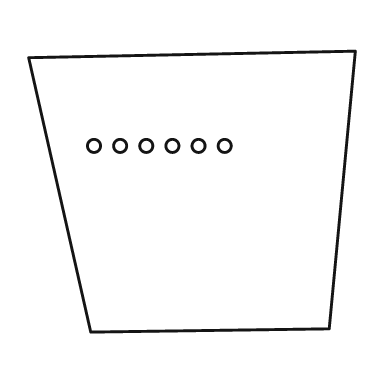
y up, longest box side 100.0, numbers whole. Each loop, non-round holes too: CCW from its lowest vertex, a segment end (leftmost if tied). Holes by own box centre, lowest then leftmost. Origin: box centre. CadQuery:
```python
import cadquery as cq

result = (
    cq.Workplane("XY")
    .moveTo(-31.0, -43.0)
    .lineTo(42.0, -42.0)
    .lineTo(50.0, 43.0)
    .lineTo(-50.0, 41.0)
    .close()
    .moveTo(-30.0, 14.0)
    .circle(2.0)
    .moveTo(-22.0, 14.0)
    .circle(2.0)
    .moveTo(-14.0, 14.0)
    .circle(2.0)
    .moveTo(-6.0, 14.0)
    .circle(2.0)
    .moveTo(2.0, 14.0)
    .circle(2.0)
    .moveTo(10.0, 14.0)
    .circle(2.0)
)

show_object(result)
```